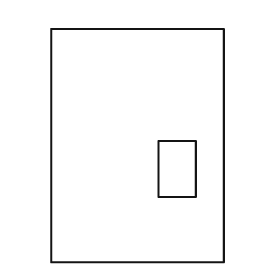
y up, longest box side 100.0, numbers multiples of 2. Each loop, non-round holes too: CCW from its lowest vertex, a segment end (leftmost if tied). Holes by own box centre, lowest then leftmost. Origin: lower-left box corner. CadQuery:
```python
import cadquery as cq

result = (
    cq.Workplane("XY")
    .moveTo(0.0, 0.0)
    .lineTo(74.0, 0.0)
    .lineTo(74.0, 100.0)
    .lineTo(0.0, 100.0)
    .close()
    .moveTo(46.0, 28.0)
    .lineTo(62.0, 28.0)
    .lineTo(62.0, 52.0)
    .lineTo(46.0, 52.0)
    .close()
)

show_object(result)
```